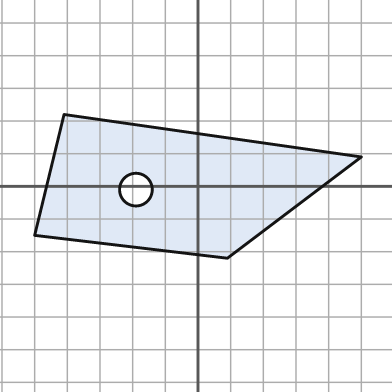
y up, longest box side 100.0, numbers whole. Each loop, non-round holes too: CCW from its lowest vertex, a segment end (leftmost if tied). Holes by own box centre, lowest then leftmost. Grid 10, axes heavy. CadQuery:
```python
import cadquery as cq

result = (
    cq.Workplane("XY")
    .moveTo(9.0, -22.0)
    .lineTo(50.0, 9.0)
    .lineTo(-41.0, 22.0)
    .lineTo(-50.0, -15.0)
    .close()
    .moveTo(-19.0, -1.0)
    .circle(5.0)
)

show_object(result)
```